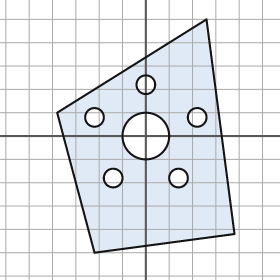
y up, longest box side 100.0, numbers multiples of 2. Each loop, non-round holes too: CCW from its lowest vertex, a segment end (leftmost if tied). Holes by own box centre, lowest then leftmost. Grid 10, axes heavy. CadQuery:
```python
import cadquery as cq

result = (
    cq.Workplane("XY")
    .moveTo(-22.0, -50.0)
    .lineTo(38.0, -42.0)
    .lineTo(26.0, 50.0)
    .lineTo(-38.0, 10.0)
    .close()
    .moveTo(-14.0, -18.0)
    .circle(4.0)
    .moveTo(14.0, -18.0)
    .circle(4.0)
    .moveTo(0.0, 0.0)
    .circle(10.0)
    .moveTo(-22.0, 8.0)
    .circle(4.0)
    .moveTo(22.0, 8.0)
    .circle(4.0)
    .moveTo(0.0, 22.0)
    .circle(4.0)
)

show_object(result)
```